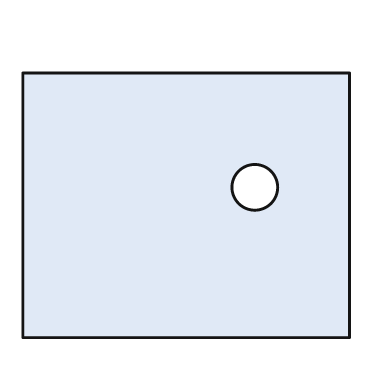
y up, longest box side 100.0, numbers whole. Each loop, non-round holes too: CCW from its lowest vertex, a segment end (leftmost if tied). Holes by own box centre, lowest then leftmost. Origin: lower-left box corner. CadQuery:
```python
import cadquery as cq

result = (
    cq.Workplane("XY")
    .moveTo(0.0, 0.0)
    .lineTo(100.0, 0.0)
    .lineTo(100.0, 81.0)
    .lineTo(0.0, 81.0)
    .close()
    .moveTo(71.0, 46.0)
    .circle(7.0)
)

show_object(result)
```